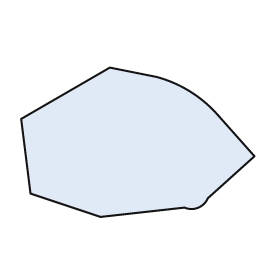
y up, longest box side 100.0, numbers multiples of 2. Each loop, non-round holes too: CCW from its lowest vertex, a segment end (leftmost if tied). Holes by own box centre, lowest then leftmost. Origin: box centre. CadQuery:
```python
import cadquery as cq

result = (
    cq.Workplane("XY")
    .moveTo(-16.0, -32.0)
    .lineTo(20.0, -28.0)
    .threePointArc((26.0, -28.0), (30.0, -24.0))
    .lineTo(50.0, -6.0)
    .lineTo(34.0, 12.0)
    .threePointArc((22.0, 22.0), (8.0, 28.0))
    .lineTo(-12.0, 32.0)
    .lineTo(-50.0, 10.0)
    .lineTo(-46.0, -22.0)
    .close()
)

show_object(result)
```